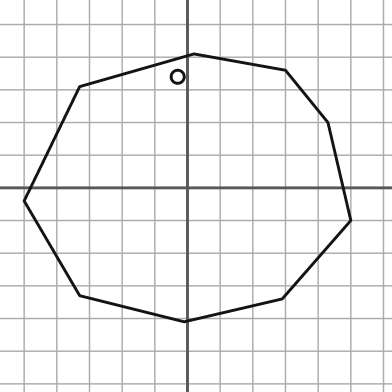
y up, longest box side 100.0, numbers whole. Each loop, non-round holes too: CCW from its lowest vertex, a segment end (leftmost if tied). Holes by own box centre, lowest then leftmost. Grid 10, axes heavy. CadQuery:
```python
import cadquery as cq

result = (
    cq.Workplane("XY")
    .moveTo(-1.0, -41.0)
    .lineTo(29.0, -34.0)
    .lineTo(50.0, -10.0)
    .lineTo(43.0, 20.0)
    .lineTo(30.0, 36.0)
    .lineTo(2.0, 41.0)
    .lineTo(-33.0, 31.0)
    .lineTo(-50.0, -4.0)
    .lineTo(-33.0, -33.0)
    .close()
    .moveTo(-3.0, 34.0)
    .circle(2.0)
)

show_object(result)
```